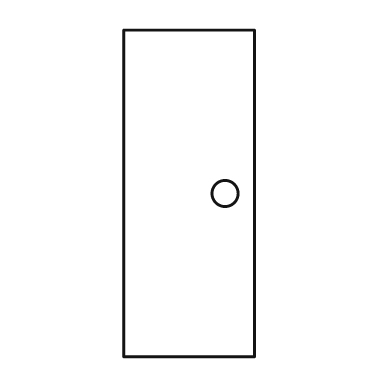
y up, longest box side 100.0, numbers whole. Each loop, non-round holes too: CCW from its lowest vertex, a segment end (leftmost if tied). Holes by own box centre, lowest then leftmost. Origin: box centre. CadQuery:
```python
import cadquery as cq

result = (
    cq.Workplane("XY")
    .moveTo(-20.0, -50.0)
    .lineTo(20.0, -50.0)
    .lineTo(20.0, 50.0)
    .lineTo(-20.0, 50.0)
    .close()
    .moveTo(11.0, 0.0)
    .circle(4.0)
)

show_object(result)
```